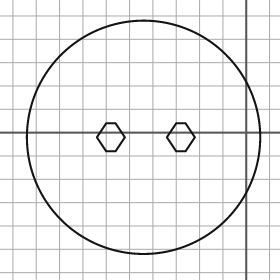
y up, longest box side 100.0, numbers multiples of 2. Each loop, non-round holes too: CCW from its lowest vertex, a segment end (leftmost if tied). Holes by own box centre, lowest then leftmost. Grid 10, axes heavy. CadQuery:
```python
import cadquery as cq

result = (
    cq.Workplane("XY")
    .moveTo(-44.0, -2.0)
    .circle(50.0)
    .moveTo(-60.0, -8.0)
    .lineTo(-56.0, -8.0)
    .lineTo(-52.0, -2.0)
    .lineTo(-56.0, 4.0)
    .lineTo(-60.0, 4.0)
    .lineTo(-64.0, -2.0)
    .close()
    .moveTo(-30.0, -8.0)
    .lineTo(-26.0, -8.0)
    .lineTo(-22.0, -2.0)
    .lineTo(-26.0, 4.0)
    .lineTo(-30.0, 4.0)
    .lineTo(-34.0, -2.0)
    .close()
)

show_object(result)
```